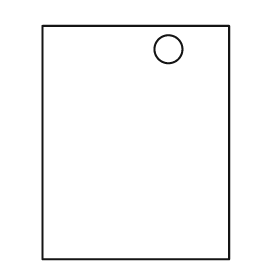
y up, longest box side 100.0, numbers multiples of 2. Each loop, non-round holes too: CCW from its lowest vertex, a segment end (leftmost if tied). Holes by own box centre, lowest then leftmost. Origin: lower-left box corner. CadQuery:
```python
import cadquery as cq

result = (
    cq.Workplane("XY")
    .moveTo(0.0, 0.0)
    .lineTo(80.0, 0.0)
    .lineTo(80.0, 100.0)
    .lineTo(0.0, 100.0)
    .close()
    .moveTo(54.0, 90.0)
    .circle(6.0)
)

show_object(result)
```